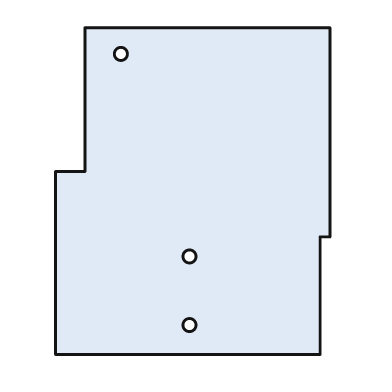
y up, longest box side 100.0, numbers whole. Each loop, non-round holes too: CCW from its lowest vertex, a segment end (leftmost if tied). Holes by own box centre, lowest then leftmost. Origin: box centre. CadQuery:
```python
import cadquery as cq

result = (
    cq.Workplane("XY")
    .moveTo(-42.0, -50.0)
    .lineTo(39.0, -50.0)
    .lineTo(39.0, -14.0)
    .lineTo(42.0, -14.0)
    .lineTo(42.0, 50.0)
    .lineTo(-33.0, 50.0)
    .lineTo(-33.0, 6.0)
    .lineTo(-42.0, 6.0)
    .close()
    .moveTo(-1.0, -41.0)
    .circle(2.0)
    .moveTo(-1.0, -20.0)
    .circle(2.0)
    .moveTo(-22.0, 42.0)
    .circle(2.0)
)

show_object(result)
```